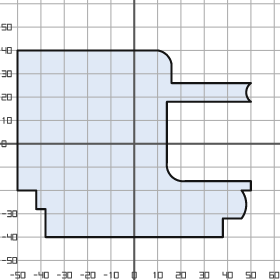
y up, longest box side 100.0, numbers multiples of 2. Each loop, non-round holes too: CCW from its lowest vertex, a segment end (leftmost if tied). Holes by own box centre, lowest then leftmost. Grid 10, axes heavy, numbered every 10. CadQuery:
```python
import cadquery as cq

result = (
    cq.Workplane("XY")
    .moveTo(-38.0, -40.0)
    .lineTo(38.0, -40.0)
    .lineTo(38.0, -32.0)
    .lineTo(46.0, -32.0)
    .threePointArc((48.0, -26.0), (46.0, -20.0))
    .lineTo(50.0, -20.0)
    .lineTo(50.0, -16.0)
    .lineTo(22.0, -16.0)
    .threePointArc((16.0, -14.0), (14.0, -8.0))
    .lineTo(14.0, 18.0)
    .lineTo(50.0, 18.0)
    .threePointArc((48.0, 22.0), (50.0, 26.0))
    .lineTo(16.0, 26.0)
    .lineTo(16.0, 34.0)
    .threePointArc((14.0, 38.0), (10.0, 40.0))
    .lineTo(-50.0, 40.0)
    .lineTo(-50.0, -20.0)
    .lineTo(-42.0, -20.0)
    .lineTo(-42.0, -28.0)
    .lineTo(-38.0, -28.0)
    .close()
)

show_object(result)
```